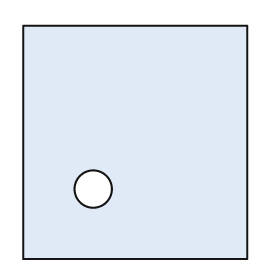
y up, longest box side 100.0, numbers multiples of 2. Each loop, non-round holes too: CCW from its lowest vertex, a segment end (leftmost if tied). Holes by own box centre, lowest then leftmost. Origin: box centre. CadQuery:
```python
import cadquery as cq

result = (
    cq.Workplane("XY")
    .moveTo(-48.0, -50.0)
    .lineTo(48.0, -50.0)
    .lineTo(48.0, 50.0)
    .lineTo(-48.0, 50.0)
    .close()
    .moveTo(-18.0, -20.0)
    .circle(8.0)
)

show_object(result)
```